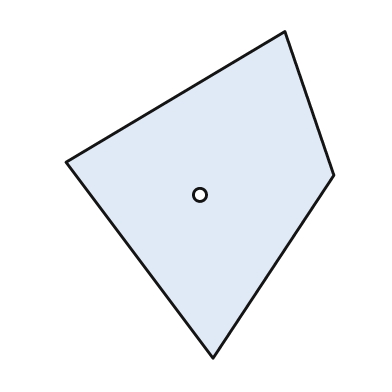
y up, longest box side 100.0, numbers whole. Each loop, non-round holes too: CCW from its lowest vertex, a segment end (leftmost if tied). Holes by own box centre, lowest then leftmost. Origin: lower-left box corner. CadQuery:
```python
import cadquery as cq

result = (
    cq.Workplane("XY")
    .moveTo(45.0, 0.0)
    .lineTo(82.0, 56.0)
    .lineTo(67.0, 100.0)
    .lineTo(0.0, 60.0)
    .close()
    .moveTo(41.0, 50.0)
    .circle(2.0)
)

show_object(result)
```